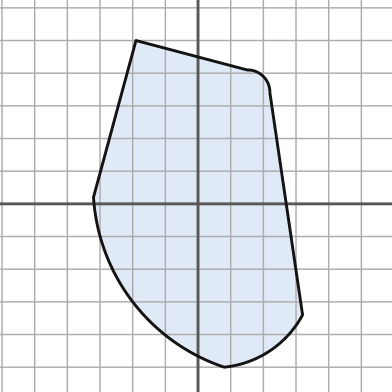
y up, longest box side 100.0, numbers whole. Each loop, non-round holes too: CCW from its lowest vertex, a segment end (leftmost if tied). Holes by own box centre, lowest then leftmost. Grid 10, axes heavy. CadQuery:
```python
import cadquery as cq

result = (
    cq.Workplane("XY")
    .moveTo(8.0, -50.0)
    .threePointArc((22.0, -45.0), (32.0, -34.0))
    .lineTo(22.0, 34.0)
    .threePointArc((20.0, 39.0), (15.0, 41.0))
    .lineTo(-19.0, 50.0)
    .lineTo(-32.0, 2.0)
    .threePointArc((-20.0, -30.0), (8.0, -50.0))
    .close()
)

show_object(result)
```